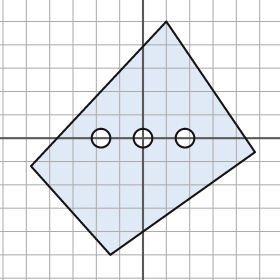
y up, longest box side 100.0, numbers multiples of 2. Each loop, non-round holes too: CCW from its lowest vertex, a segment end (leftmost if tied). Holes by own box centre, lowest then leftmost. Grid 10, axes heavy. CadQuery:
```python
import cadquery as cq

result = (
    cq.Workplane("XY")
    .moveTo(-14.0, -50.0)
    .lineTo(48.0, -6.0)
    .lineTo(10.0, 50.0)
    .lineTo(-48.0, -12.0)
    .close()
    .moveTo(-18.0, 0.0)
    .circle(4.0)
    .moveTo(0.0, 0.0)
    .circle(4.0)
    .moveTo(18.0, 0.0)
    .circle(4.0)
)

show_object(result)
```